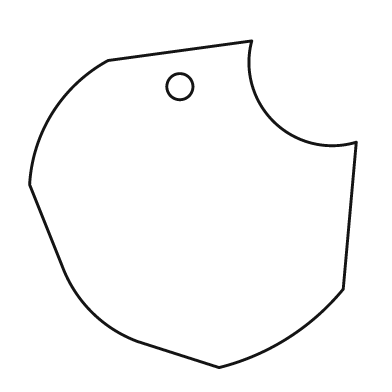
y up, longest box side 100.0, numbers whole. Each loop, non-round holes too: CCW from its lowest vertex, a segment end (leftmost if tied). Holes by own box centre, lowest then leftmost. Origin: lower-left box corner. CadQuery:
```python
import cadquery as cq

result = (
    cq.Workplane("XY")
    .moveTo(58.0, 0.0)
    .threePointArc((79.0, 9.0), (96.0, 24.0))
    .lineTo(100.0, 69.0)
    .threePointArc((75.0, 75.0), (68.0, 100.0))
    .lineTo(24.0, 94.0)
    .threePointArc((7.0, 78.0), (0.0, 56.0))
    .lineTo(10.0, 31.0)
    .threePointArc((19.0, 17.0), (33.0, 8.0))
    .close()
    .moveTo(46.0, 86.0)
    .circle(4.0)
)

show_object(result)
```